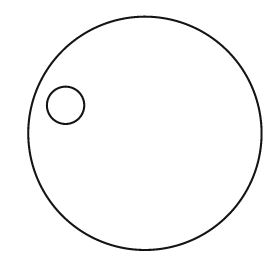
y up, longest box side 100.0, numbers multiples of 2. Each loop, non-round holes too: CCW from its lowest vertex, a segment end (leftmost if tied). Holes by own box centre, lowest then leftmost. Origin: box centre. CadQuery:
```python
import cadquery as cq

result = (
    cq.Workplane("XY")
    .moveTo(0.0, 0.0)
    .circle(50.0)
    .moveTo(-34.0, 12.0)
    .circle(8.0)
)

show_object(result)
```